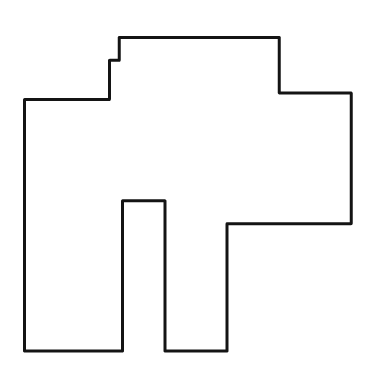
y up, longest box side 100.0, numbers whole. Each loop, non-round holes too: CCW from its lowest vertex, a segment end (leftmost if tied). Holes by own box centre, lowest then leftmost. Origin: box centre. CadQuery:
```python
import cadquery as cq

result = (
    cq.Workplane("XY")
    .moveTo(-50.0, -48.0)
    .lineTo(-20.0, -48.0)
    .lineTo(-20.0, -2.0)
    .lineTo(-7.0, -2.0)
    .lineTo(-7.0, -48.0)
    .lineTo(12.0, -48.0)
    .lineTo(12.0, -9.0)
    .lineTo(50.0, -9.0)
    .lineTo(50.0, 31.0)
    .lineTo(28.0, 31.0)
    .lineTo(28.0, 48.0)
    .lineTo(-21.0, 48.0)
    .lineTo(-21.0, 41.0)
    .lineTo(-24.0, 41.0)
    .lineTo(-24.0, 29.0)
    .lineTo(-50.0, 29.0)
    .close()
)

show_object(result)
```